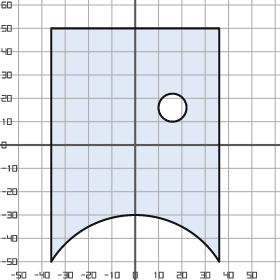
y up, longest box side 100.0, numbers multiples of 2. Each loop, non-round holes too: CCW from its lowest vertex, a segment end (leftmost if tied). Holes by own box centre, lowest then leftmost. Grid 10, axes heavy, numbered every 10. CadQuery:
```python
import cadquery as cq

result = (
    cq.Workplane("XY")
    .moveTo(-36.0, -50.0)
    .threePointArc((0.0, -30.0), (36.0, -50.0))
    .lineTo(36.0, 50.0)
    .lineTo(-36.0, 50.0)
    .close()
    .moveTo(16.0, 16.0)
    .circle(6.0)
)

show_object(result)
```